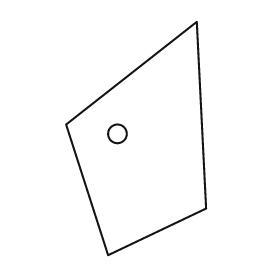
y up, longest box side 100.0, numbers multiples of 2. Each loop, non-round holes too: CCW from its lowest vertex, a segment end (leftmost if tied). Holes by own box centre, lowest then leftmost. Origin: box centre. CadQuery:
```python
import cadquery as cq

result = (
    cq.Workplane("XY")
    .moveTo(-12.0, -50.0)
    .lineTo(30.0, -30.0)
    .lineTo(26.0, 50.0)
    .lineTo(-30.0, 6.0)
    .close()
    .moveTo(-8.0, 2.0)
    .circle(4.0)
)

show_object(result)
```